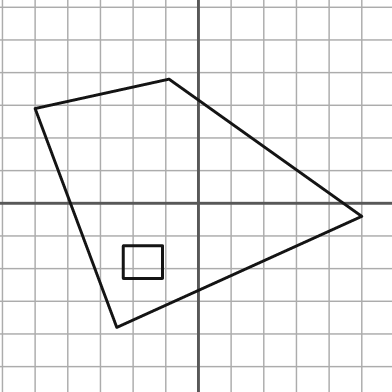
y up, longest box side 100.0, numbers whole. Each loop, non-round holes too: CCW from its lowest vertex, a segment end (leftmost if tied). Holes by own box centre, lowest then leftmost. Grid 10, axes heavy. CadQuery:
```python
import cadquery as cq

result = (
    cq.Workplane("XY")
    .moveTo(-25.0, -38.0)
    .lineTo(50.0, -4.0)
    .lineTo(-9.0, 38.0)
    .lineTo(-50.0, 29.0)
    .close()
    .moveTo(-23.0, -23.0)
    .lineTo(-11.0, -23.0)
    .lineTo(-11.0, -13.0)
    .lineTo(-23.0, -13.0)
    .close()
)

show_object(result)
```